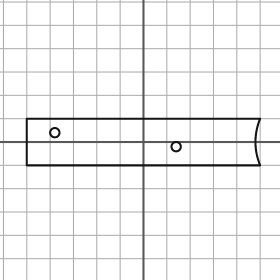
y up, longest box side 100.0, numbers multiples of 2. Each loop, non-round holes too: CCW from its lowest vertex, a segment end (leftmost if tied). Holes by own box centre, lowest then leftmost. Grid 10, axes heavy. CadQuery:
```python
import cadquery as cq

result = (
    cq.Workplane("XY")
    .moveTo(-50.0, -10.0)
    .lineTo(50.0, -10.0)
    .threePointArc((48.0, 0.0), (50.0, 10.0))
    .lineTo(-50.0, 10.0)
    .close()
    .moveTo(14.0, -2.0)
    .circle(2.0)
    .moveTo(-38.0, 4.0)
    .circle(2.0)
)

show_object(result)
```